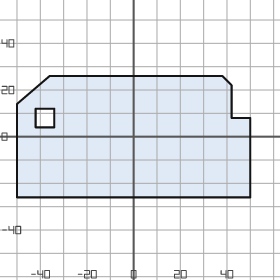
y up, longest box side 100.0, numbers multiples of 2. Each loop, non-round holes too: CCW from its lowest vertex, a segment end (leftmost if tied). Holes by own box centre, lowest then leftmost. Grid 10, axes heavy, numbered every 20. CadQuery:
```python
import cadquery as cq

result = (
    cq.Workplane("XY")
    .moveTo(-50.0, -26.0)
    .lineTo(50.0, -26.0)
    .lineTo(50.0, 8.0)
    .lineTo(42.0, 8.0)
    .lineTo(42.0, 22.0)
    .lineTo(38.0, 26.0)
    .lineTo(-36.0, 26.0)
    .lineTo(-50.0, 14.0)
    .close()
    .moveTo(-42.0, 4.0)
    .lineTo(-34.0, 4.0)
    .lineTo(-34.0, 12.0)
    .lineTo(-42.0, 12.0)
    .close()
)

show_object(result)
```